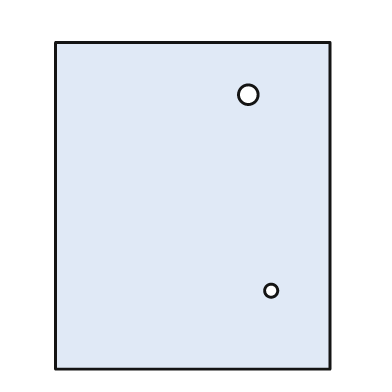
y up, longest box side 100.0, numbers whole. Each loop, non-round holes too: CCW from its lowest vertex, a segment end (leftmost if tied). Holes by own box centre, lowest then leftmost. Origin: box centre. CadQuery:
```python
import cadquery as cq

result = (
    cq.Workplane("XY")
    .moveTo(-42.0, -50.0)
    .lineTo(42.0, -50.0)
    .lineTo(42.0, 50.0)
    .lineTo(-42.0, 50.0)
    .close()
    .moveTo(24.0, -26.0)
    .circle(2.0)
    .moveTo(17.0, 34.0)
    .circle(3.0)
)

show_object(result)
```